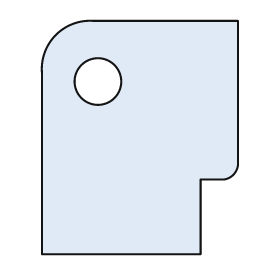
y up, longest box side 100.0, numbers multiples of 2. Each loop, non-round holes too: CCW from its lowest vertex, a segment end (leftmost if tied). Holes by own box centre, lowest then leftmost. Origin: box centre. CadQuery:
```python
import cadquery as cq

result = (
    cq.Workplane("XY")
    .moveTo(-42.0, -50.0)
    .lineTo(26.0, -50.0)
    .lineTo(26.0, -18.0)
    .lineTo(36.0, -18.0)
    .threePointArc((40.0, -16.0), (42.0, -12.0))
    .lineTo(42.0, 50.0)
    .lineTo(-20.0, 50.0)
    .threePointArc((-36.0, 44.0), (-42.0, 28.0))
    .close()
    .moveTo(-18.0, 24.0)
    .circle(10.0)
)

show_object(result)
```